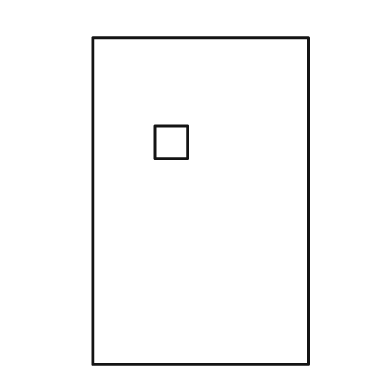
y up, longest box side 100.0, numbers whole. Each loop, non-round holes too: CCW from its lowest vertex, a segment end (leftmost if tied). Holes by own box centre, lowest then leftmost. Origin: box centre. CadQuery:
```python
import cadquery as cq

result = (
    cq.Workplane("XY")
    .moveTo(-33.0, -50.0)
    .lineTo(33.0, -50.0)
    .lineTo(33.0, 50.0)
    .lineTo(-33.0, 50.0)
    .close()
    .moveTo(-14.0, 13.0)
    .lineTo(-4.0, 13.0)
    .lineTo(-4.0, 23.0)
    .lineTo(-14.0, 23.0)
    .close()
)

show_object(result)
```